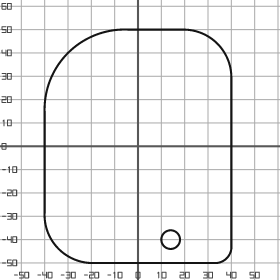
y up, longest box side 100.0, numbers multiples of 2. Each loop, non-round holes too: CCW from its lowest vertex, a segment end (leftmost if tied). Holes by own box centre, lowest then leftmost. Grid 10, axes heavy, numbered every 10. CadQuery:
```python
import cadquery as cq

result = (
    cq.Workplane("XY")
    .moveTo(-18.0, -50.0)
    .lineTo(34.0, -50.0)
    .threePointArc((38.0, -48.0), (40.0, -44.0))
    .lineTo(40.0, 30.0)
    .threePointArc((34.0, 44.0), (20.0, 50.0))
    .lineTo(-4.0, 50.0)
    .threePointArc((-30.0, 40.0), (-40.0, 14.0))
    .lineTo(-40.0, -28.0)
    .threePointArc((-34.0, -44.0), (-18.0, -50.0))
    .close()
    .moveTo(14.0, -40.0)
    .circle(4.0)
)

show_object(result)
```